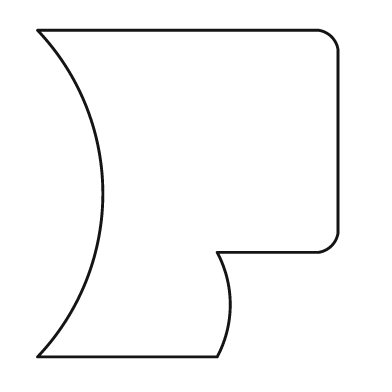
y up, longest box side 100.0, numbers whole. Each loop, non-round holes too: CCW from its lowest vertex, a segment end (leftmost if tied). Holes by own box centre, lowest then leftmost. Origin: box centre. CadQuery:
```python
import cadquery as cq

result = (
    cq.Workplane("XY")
    .moveTo(-46.0, -50.0)
    .lineTo(9.0, -50.0)
    .threePointArc((13.0, -34.0), (9.0, -18.0))
    .lineTo(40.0, -18.0)
    .threePointArc((44.0, -16.0), (46.0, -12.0))
    .lineTo(46.0, 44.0)
    .threePointArc((44.0, 48.0), (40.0, 50.0))
    .lineTo(-46.0, 50.0)
    .threePointArc((-26.0, 0.0), (-46.0, -50.0))
    .close()
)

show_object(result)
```